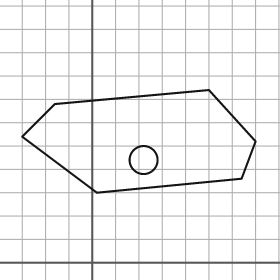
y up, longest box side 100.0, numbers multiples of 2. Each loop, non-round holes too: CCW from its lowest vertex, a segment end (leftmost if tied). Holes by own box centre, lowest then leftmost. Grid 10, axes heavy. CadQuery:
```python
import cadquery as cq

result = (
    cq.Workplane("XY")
    .moveTo(2.0, 30.0)
    .lineTo(64.0, 36.0)
    .lineTo(70.0, 52.0)
    .lineTo(50.0, 74.0)
    .lineTo(-16.0, 68.0)
    .lineTo(-30.0, 54.0)
    .close()
    .moveTo(22.0, 44.0)
    .circle(6.0)
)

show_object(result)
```